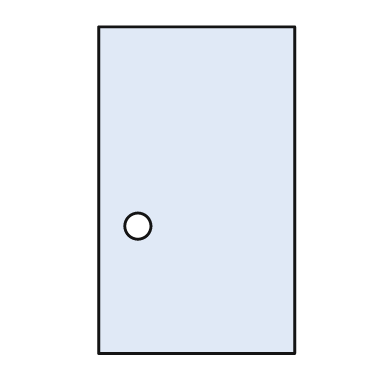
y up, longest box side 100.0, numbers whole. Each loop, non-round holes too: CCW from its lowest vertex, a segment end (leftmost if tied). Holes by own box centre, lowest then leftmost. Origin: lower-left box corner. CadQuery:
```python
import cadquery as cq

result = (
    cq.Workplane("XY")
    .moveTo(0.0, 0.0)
    .lineTo(60.0, 0.0)
    .lineTo(60.0, 100.0)
    .lineTo(0.0, 100.0)
    .close()
    .moveTo(12.0, 39.0)
    .circle(4.0)
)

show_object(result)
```